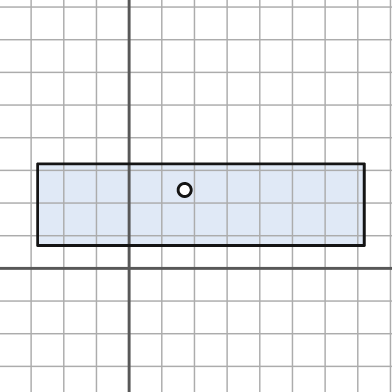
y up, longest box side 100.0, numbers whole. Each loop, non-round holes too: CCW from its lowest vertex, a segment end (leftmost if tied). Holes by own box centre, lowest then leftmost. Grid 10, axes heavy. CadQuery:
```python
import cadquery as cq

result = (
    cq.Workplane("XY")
    .moveTo(-28.0, 7.0)
    .lineTo(72.0, 7.0)
    .lineTo(72.0, 32.0)
    .lineTo(-28.0, 32.0)
    .close()
    .moveTo(17.0, 24.0)
    .circle(2.0)
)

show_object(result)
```